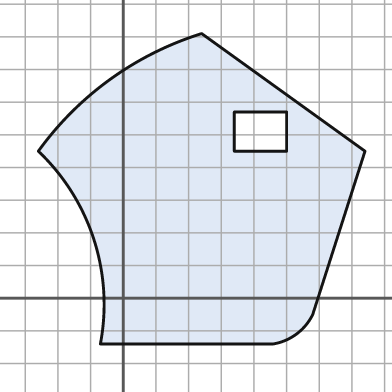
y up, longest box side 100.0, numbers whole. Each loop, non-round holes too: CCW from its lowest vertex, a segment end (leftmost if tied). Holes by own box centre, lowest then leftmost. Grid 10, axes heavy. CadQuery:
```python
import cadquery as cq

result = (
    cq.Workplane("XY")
    .moveTo(-7.0, -14.0)
    .lineTo(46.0, -14.0)
    .threePointArc((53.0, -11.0), (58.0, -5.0))
    .lineTo(74.0, 45.0)
    .lineTo(24.0, 81.0)
    .threePointArc((-4.0, 67.0), (-26.0, 45.0))
    .threePointArc((-9.0, 18.0), (-7.0, -14.0))
    .close()
    .moveTo(34.0, 45.0)
    .lineTo(50.0, 45.0)
    .lineTo(50.0, 57.0)
    .lineTo(34.0, 57.0)
    .close()
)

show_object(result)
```